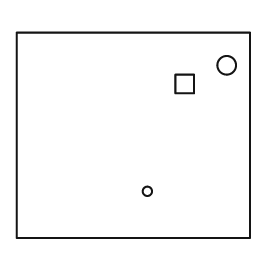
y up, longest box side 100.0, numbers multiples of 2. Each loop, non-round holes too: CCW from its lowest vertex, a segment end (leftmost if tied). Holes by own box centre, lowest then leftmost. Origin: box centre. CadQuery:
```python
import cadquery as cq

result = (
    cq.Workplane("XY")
    .moveTo(-50.0, -44.0)
    .lineTo(50.0, -44.0)
    .lineTo(50.0, 44.0)
    .lineTo(-50.0, 44.0)
    .close()
    .moveTo(6.0, -24.0)
    .circle(2.0)
    .moveTo(18.0, 18.0)
    .lineTo(26.0, 18.0)
    .lineTo(26.0, 26.0)
    .lineTo(18.0, 26.0)
    .close()
    .moveTo(40.0, 30.0)
    .circle(4.0)
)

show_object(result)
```